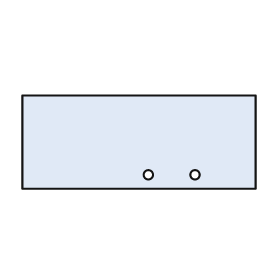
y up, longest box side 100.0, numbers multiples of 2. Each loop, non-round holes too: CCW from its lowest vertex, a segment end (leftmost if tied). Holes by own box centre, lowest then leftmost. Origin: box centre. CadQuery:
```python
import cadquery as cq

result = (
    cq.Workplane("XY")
    .moveTo(-50.0, -20.0)
    .lineTo(50.0, -20.0)
    .lineTo(50.0, 20.0)
    .lineTo(-50.0, 20.0)
    .close()
    .moveTo(4.0, -14.0)
    .circle(2.0)
    .moveTo(24.0, -14.0)
    .circle(2.0)
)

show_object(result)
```